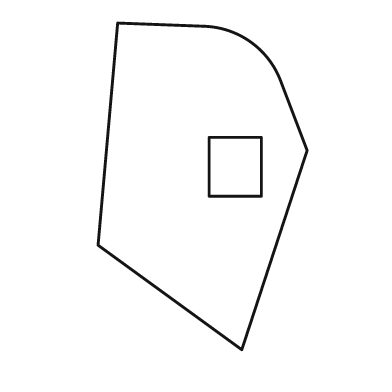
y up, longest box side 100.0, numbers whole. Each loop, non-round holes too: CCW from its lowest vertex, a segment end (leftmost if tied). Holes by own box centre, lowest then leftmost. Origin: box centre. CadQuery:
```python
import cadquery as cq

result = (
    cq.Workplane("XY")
    .moveTo(12.0, -50.0)
    .lineTo(32.0, 11.0)
    .lineTo(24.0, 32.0)
    .threePointArc((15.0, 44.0), (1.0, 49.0))
    .lineTo(-26.0, 50.0)
    .lineTo(-32.0, -18.0)
    .close()
    .moveTo(2.0, -3.0)
    .lineTo(18.0, -3.0)
    .lineTo(18.0, 15.0)
    .lineTo(2.0, 15.0)
    .close()
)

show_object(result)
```